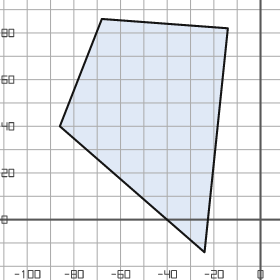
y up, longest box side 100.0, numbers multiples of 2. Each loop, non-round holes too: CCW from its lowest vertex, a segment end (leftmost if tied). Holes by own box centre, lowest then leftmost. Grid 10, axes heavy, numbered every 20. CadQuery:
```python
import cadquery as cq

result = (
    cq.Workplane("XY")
    .moveTo(-24.0, -14.0)
    .lineTo(-14.0, 82.0)
    .lineTo(-68.0, 86.0)
    .lineTo(-86.0, 40.0)
    .close()
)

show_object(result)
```